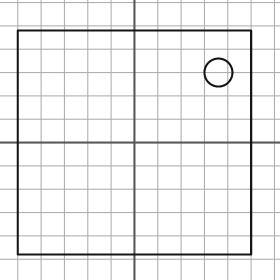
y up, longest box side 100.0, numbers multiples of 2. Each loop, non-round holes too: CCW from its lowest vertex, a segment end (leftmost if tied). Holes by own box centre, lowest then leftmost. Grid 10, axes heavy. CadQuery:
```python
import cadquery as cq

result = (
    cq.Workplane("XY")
    .moveTo(-50.0, -48.0)
    .lineTo(50.0, -48.0)
    .lineTo(50.0, 48.0)
    .lineTo(-50.0, 48.0)
    .close()
    .moveTo(36.0, 30.0)
    .circle(6.0)
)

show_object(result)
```